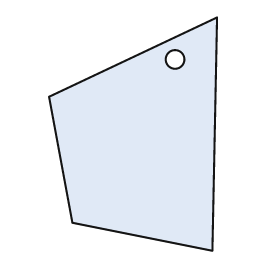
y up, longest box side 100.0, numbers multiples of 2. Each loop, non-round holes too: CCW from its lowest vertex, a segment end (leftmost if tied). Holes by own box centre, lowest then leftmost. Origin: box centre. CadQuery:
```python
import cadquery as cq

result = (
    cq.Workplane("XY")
    .moveTo(34.0, -50.0)
    .lineTo(36.0, 50.0)
    .lineTo(-36.0, 16.0)
    .lineTo(-26.0, -38.0)
    .close()
    .moveTo(18.0, 32.0)
    .circle(4.0)
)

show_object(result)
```